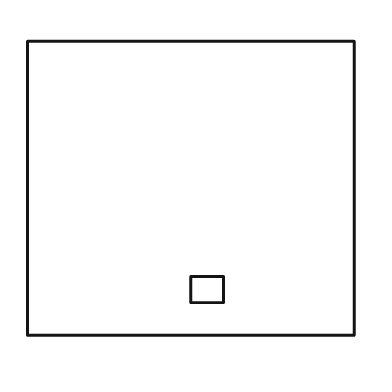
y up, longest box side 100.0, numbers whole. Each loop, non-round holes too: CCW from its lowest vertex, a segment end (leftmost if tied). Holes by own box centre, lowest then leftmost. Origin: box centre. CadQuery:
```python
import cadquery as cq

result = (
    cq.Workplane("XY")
    .moveTo(-50.0, -45.0)
    .lineTo(50.0, -45.0)
    .lineTo(50.0, 45.0)
    .lineTo(-50.0, 45.0)
    .close()
    .moveTo(0.0, -35.0)
    .lineTo(10.0, -35.0)
    .lineTo(10.0, -27.0)
    .lineTo(0.0, -27.0)
    .close()
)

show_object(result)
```